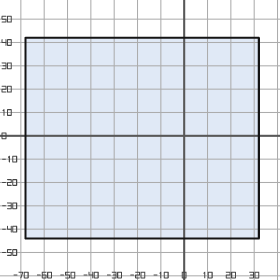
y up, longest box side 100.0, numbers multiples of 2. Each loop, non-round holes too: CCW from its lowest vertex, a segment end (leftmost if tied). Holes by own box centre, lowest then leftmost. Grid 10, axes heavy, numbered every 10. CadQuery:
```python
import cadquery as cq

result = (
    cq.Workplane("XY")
    .moveTo(-68.0, -44.0)
    .lineTo(32.0, -44.0)
    .lineTo(32.0, 42.0)
    .lineTo(-68.0, 42.0)
    .close()
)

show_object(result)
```